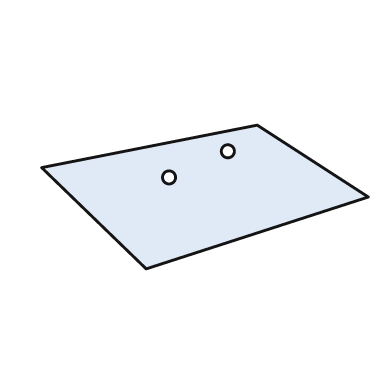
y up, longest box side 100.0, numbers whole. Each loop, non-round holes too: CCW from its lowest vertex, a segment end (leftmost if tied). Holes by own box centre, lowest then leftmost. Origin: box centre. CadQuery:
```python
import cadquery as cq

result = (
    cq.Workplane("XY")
    .moveTo(-18.0, -22.0)
    .lineTo(50.0, 0.0)
    .lineTo(16.0, 22.0)
    .lineTo(-50.0, 9.0)
    .close()
    .moveTo(-11.0, 6.0)
    .circle(2.0)
    .moveTo(7.0, 14.0)
    .circle(2.0)
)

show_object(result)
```